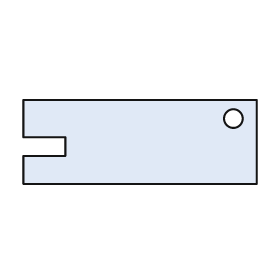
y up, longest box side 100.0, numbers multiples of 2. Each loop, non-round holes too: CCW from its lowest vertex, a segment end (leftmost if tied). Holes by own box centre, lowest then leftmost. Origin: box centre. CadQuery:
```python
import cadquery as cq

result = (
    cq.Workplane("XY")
    .moveTo(-50.0, -18.0)
    .lineTo(50.0, -18.0)
    .lineTo(50.0, 18.0)
    .lineTo(-50.0, 18.0)
    .lineTo(-50.0, 2.0)
    .lineTo(-32.0, 2.0)
    .lineTo(-32.0, -6.0)
    .lineTo(-50.0, -6.0)
    .close()
    .moveTo(40.0, 10.0)
    .circle(4.0)
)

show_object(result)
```